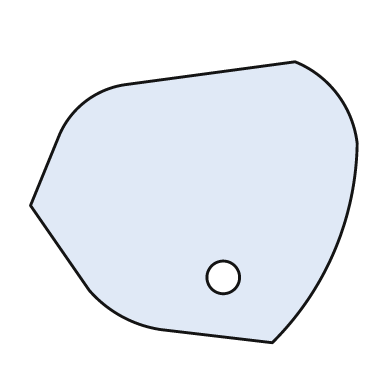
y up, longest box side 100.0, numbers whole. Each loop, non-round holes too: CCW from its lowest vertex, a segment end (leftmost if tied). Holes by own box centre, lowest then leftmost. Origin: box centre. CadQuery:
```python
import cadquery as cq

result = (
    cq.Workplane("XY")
    .moveTo(24.0, -43.0)
    .threePointArc((43.0, -15.0), (50.0, 18.0))
    .threePointArc((44.0, 33.0), (31.0, 43.0))
    .lineTo(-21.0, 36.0)
    .threePointArc((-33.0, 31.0), (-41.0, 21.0))
    .lineTo(-50.0, -1.0)
    .lineTo(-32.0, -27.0)
    .threePointArc((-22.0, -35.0), (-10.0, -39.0))
    .close()
    .moveTo(9.0, -23.0)
    .circle(5.0)
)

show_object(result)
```